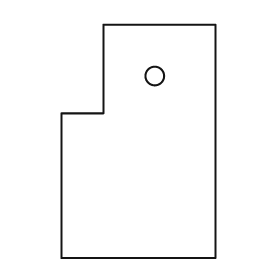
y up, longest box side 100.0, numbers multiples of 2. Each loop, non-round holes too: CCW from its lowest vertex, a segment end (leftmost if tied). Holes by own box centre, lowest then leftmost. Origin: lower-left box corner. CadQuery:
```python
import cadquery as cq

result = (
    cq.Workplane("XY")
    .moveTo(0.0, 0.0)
    .lineTo(66.0, 0.0)
    .lineTo(66.0, 100.0)
    .lineTo(18.0, 100.0)
    .lineTo(18.0, 62.0)
    .lineTo(0.0, 62.0)
    .close()
    .moveTo(40.0, 78.0)
    .circle(4.0)
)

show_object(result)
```